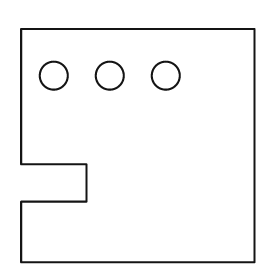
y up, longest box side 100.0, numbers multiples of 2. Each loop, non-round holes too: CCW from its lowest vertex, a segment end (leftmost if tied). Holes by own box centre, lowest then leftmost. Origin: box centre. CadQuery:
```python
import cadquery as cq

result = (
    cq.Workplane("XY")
    .moveTo(-50.0, -50.0)
    .lineTo(50.0, -50.0)
    .lineTo(50.0, 50.0)
    .lineTo(-50.0, 50.0)
    .lineTo(-50.0, -8.0)
    .lineTo(-22.0, -8.0)
    .lineTo(-22.0, -24.0)
    .lineTo(-50.0, -24.0)
    .close()
    .moveTo(-36.0, 30.0)
    .circle(6.0)
    .moveTo(-12.0, 30.0)
    .circle(6.0)
    .moveTo(12.0, 30.0)
    .circle(6.0)
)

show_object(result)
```